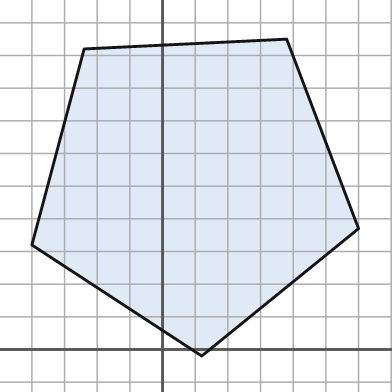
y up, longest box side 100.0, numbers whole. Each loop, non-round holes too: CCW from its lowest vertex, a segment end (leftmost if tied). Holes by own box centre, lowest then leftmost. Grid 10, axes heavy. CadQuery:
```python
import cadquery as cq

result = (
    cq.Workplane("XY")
    .moveTo(12.0, -2.0)
    .lineTo(60.0, 37.0)
    .lineTo(38.0, 95.0)
    .lineTo(-24.0, 92.0)
    .lineTo(-40.0, 32.0)
    .close()
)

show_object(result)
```